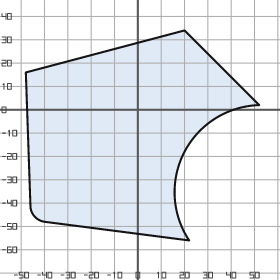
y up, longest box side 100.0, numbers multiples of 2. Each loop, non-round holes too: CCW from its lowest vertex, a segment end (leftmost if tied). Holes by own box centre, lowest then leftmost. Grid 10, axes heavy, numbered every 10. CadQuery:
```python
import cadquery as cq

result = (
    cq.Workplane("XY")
    .moveTo(22.0, -56.0)
    .threePointArc((20.0, -18.0), (52.0, 2.0))
    .lineTo(20.0, 34.0)
    .lineTo(-48.0, 16.0)
    .lineTo(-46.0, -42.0)
    .threePointArc((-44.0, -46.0), (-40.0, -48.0))
    .close()
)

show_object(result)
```